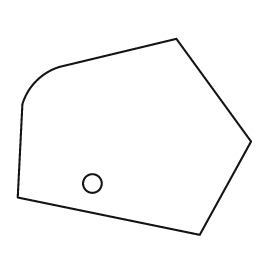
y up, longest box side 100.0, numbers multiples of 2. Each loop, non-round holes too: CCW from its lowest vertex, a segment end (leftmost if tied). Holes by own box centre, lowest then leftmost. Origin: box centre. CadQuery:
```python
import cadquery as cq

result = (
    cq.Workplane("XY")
    .moveTo(28.0, -42.0)
    .lineTo(50.0, -2.0)
    .lineTo(18.0, 42.0)
    .lineTo(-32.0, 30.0)
    .threePointArc((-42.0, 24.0), (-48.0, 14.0))
    .lineTo(-50.0, -26.0)
    .close()
    .moveTo(-18.0, -20.0)
    .circle(4.0)
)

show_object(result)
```